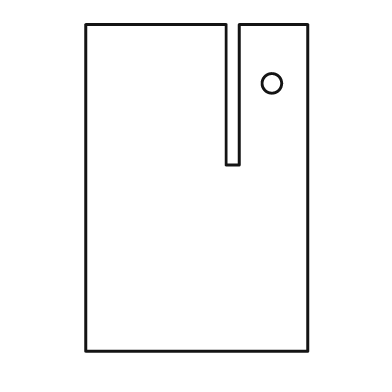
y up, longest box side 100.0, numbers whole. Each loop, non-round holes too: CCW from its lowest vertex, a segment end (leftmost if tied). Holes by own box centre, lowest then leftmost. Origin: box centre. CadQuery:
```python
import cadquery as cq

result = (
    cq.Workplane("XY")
    .moveTo(-34.0, -50.0)
    .lineTo(34.0, -50.0)
    .lineTo(34.0, 50.0)
    .lineTo(13.0, 50.0)
    .lineTo(13.0, 7.0)
    .lineTo(9.0, 7.0)
    .lineTo(9.0, 50.0)
    .lineTo(-34.0, 50.0)
    .close()
    .moveTo(23.0, 32.0)
    .circle(3.0)
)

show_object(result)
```